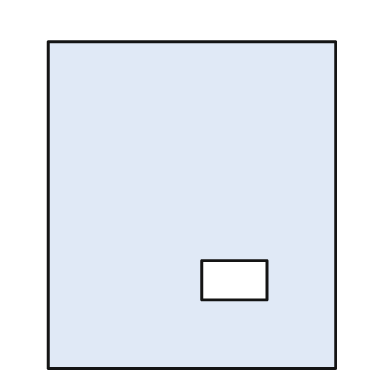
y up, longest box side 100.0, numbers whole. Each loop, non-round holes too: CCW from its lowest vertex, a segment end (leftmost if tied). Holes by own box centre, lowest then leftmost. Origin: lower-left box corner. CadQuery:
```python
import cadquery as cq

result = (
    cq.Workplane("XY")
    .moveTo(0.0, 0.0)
    .lineTo(88.0, 0.0)
    .lineTo(88.0, 100.0)
    .lineTo(0.0, 100.0)
    .close()
    .moveTo(47.0, 21.0)
    .lineTo(67.0, 21.0)
    .lineTo(67.0, 33.0)
    .lineTo(47.0, 33.0)
    .close()
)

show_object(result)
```